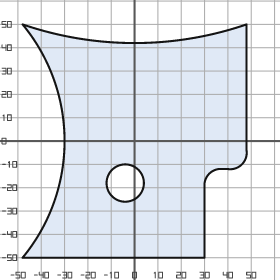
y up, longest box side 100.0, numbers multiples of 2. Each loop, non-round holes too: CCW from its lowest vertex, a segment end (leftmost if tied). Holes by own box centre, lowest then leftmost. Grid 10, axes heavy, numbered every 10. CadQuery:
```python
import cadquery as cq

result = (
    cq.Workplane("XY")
    .moveTo(-48.0, -50.0)
    .lineTo(30.0, -50.0)
    .lineTo(30.0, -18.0)
    .threePointArc((32.0, -14.0), (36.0, -12.0))
    .lineTo(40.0, -12.0)
    .threePointArc((46.0, -10.0), (48.0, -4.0))
    .lineTo(48.0, 50.0)
    .threePointArc((0.0, 42.0), (-48.0, 50.0))
    .threePointArc((-30.0, 0.0), (-48.0, -50.0))
    .close()
    .moveTo(-4.0, -18.0)
    .circle(8.0)
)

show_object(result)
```